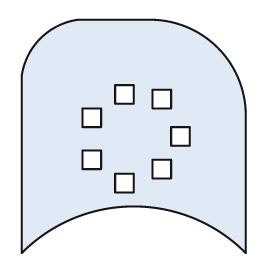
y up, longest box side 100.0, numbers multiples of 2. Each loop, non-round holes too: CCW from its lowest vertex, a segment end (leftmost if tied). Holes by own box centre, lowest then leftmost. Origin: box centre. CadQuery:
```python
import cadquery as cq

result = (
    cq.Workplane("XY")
    .moveTo(-48.0, -50.0)
    .threePointArc((0.0, -30.0), (48.0, -50.0))
    .lineTo(48.0, 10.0)
    .threePointArc((36.0, 38.0), (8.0, 50.0))
    .lineTo(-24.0, 50.0)
    .threePointArc((-40.0, 42.0), (-48.0, 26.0))
    .close()
    .moveTo(-8.0, -24.0)
    .lineTo(0.0, -24.0)
    .lineTo(0.0, -16.0)
    .lineTo(-8.0, -16.0)
    .close()
    .moveTo(8.0, -18.0)
    .lineTo(16.0, -18.0)
    .lineTo(16.0, -10.0)
    .lineTo(8.0, -10.0)
    .close()
    .moveTo(-22.0, -14.0)
    .lineTo(-14.0, -14.0)
    .lineTo(-14.0, -6.0)
    .lineTo(-22.0, -6.0)
    .close()
    .moveTo(16.0, -4.0)
    .lineTo(24.0, -4.0)
    .lineTo(24.0, 4.0)
    .lineTo(16.0, 4.0)
    .close()
    .moveTo(-22.0, 4.0)
    .lineTo(-14.0, 4.0)
    .lineTo(-14.0, 12.0)
    .lineTo(-22.0, 12.0)
    .close()
    .moveTo(8.0, 12.0)
    .lineTo(16.0, 12.0)
    .lineTo(16.0, 20.0)
    .lineTo(8.0, 20.0)
    .close()
    .moveTo(-8.0, 14.0)
    .lineTo(0.0, 14.0)
    .lineTo(0.0, 22.0)
    .lineTo(-8.0, 22.0)
    .close()
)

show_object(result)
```